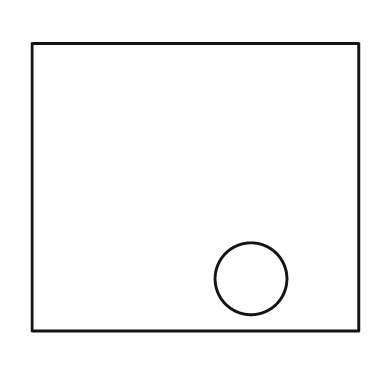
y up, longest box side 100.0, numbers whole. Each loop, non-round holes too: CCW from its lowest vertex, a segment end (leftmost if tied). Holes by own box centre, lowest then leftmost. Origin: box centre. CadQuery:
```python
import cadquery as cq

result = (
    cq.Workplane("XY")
    .moveTo(-50.0, -44.0)
    .lineTo(50.0, -44.0)
    .lineTo(50.0, 44.0)
    .lineTo(-50.0, 44.0)
    .close()
    .moveTo(17.0, -28.0)
    .circle(11.0)
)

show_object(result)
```